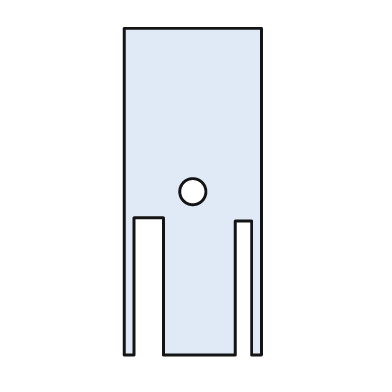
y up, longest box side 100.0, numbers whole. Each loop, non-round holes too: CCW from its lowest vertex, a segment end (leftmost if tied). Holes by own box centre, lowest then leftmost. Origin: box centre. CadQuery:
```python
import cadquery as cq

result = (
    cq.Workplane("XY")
    .moveTo(-21.0, -50.0)
    .lineTo(-18.0, -50.0)
    .lineTo(-18.0, -8.0)
    .lineTo(-9.0, -8.0)
    .lineTo(-9.0, -50.0)
    .lineTo(13.0, -50.0)
    .lineTo(13.0, -9.0)
    .lineTo(18.0, -9.0)
    .lineTo(18.0, -50.0)
    .lineTo(21.0, -50.0)
    .lineTo(21.0, 50.0)
    .lineTo(-21.0, 50.0)
    .close()
    .moveTo(0.0, 0.0)
    .circle(4.0)
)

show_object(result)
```